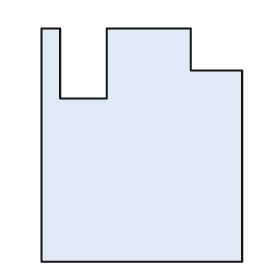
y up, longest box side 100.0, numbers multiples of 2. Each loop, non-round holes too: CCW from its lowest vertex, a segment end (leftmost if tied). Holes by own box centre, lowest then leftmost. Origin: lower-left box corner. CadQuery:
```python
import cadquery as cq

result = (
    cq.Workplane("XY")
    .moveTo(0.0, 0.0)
    .lineTo(86.0, 0.0)
    .lineTo(86.0, 82.0)
    .lineTo(64.0, 82.0)
    .lineTo(64.0, 100.0)
    .lineTo(28.0, 100.0)
    .lineTo(28.0, 70.0)
    .lineTo(8.0, 70.0)
    .lineTo(8.0, 100.0)
    .lineTo(0.0, 100.0)
    .close()
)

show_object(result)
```